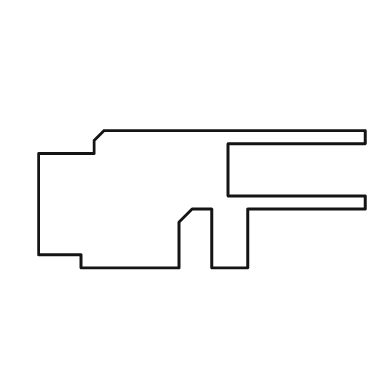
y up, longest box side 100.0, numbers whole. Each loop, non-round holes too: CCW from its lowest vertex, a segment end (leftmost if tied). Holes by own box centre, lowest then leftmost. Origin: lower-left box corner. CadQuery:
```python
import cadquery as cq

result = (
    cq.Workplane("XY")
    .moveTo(13.0, 0.0)
    .lineTo(43.0, 0.0)
    .lineTo(43.0, 14.0)
    .lineTo(47.0, 18.0)
    .lineTo(53.0, 18.0)
    .lineTo(53.0, 0.0)
    .lineTo(64.0, 0.0)
    .lineTo(64.0, 18.0)
    .lineTo(100.0, 18.0)
    .lineTo(100.0, 22.0)
    .lineTo(58.0, 22.0)
    .lineTo(58.0, 38.0)
    .lineTo(100.0, 38.0)
    .lineTo(100.0, 42.0)
    .lineTo(20.0, 42.0)
    .lineTo(17.0, 39.0)
    .lineTo(17.0, 35.0)
    .lineTo(0.0, 35.0)
    .lineTo(0.0, 4.0)
    .lineTo(13.0, 4.0)
    .close()
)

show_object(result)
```